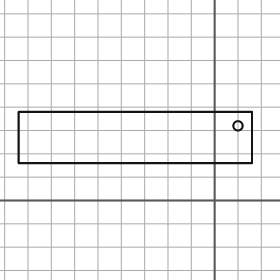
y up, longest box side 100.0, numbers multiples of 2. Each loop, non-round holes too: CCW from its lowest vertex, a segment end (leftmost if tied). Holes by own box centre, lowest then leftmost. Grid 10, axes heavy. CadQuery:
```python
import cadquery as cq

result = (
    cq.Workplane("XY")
    .moveTo(-84.0, 16.0)
    .lineTo(16.0, 16.0)
    .lineTo(16.0, 38.0)
    .lineTo(-84.0, 38.0)
    .close()
    .moveTo(10.0, 32.0)
    .circle(2.0)
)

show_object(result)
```